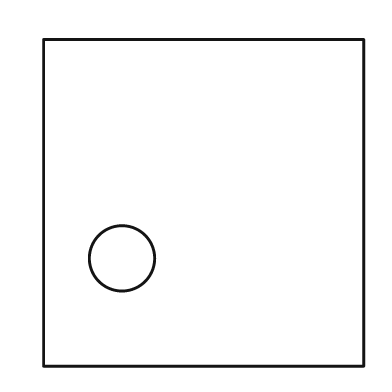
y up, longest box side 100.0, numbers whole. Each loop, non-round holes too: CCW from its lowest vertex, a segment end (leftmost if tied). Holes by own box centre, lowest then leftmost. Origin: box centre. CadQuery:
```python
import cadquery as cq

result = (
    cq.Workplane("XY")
    .moveTo(-49.0, -50.0)
    .lineTo(49.0, -50.0)
    .lineTo(49.0, 50.0)
    .lineTo(-49.0, 50.0)
    .close()
    .moveTo(-25.0, -17.0)
    .circle(10.0)
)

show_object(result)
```